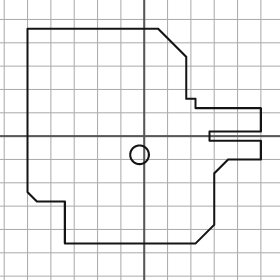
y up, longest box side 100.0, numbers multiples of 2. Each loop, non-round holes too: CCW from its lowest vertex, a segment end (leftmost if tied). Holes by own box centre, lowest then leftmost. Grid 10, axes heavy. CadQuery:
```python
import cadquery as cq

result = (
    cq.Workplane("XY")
    .moveTo(-34.0, -46.0)
    .lineTo(22.0, -46.0)
    .lineTo(30.0, -38.0)
    .lineTo(30.0, -16.0)
    .lineTo(36.0, -10.0)
    .lineTo(50.0, -10.0)
    .lineTo(50.0, -2.0)
    .lineTo(28.0, -2.0)
    .lineTo(28.0, 2.0)
    .lineTo(50.0, 2.0)
    .lineTo(50.0, 12.0)
    .lineTo(22.0, 12.0)
    .lineTo(22.0, 16.0)
    .lineTo(18.0, 16.0)
    .lineTo(18.0, 34.0)
    .lineTo(6.0, 46.0)
    .lineTo(-50.0, 46.0)
    .lineTo(-50.0, -24.0)
    .lineTo(-46.0, -28.0)
    .lineTo(-34.0, -28.0)
    .close()
    .moveTo(-2.0, -8.0)
    .circle(4.0)
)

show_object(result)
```